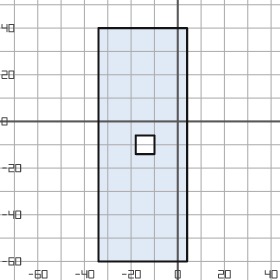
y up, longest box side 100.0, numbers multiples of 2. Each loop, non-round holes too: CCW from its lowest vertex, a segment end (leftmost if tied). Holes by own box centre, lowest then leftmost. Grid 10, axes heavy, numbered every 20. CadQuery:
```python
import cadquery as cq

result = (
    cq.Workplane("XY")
    .moveTo(-34.0, -60.0)
    .lineTo(4.0, -60.0)
    .lineTo(4.0, 40.0)
    .lineTo(-34.0, 40.0)
    .close()
    .moveTo(-18.0, -14.0)
    .lineTo(-10.0, -14.0)
    .lineTo(-10.0, -6.0)
    .lineTo(-18.0, -6.0)
    .close()
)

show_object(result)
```